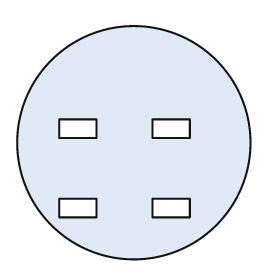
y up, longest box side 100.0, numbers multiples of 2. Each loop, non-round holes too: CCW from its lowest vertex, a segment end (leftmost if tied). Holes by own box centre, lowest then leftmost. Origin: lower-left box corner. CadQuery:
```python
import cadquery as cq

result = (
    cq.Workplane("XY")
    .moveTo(50.0, 50.0)
    .circle(50.0)
    .moveTo(18.0, 18.0)
    .lineTo(34.0, 18.0)
    .lineTo(34.0, 26.0)
    .lineTo(18.0, 26.0)
    .close()
    .moveTo(58.0, 18.0)
    .lineTo(74.0, 18.0)
    .lineTo(74.0, 26.0)
    .lineTo(58.0, 26.0)
    .close()
    .moveTo(18.0, 52.0)
    .lineTo(34.0, 52.0)
    .lineTo(34.0, 60.0)
    .lineTo(18.0, 60.0)
    .close()
    .moveTo(58.0, 52.0)
    .lineTo(74.0, 52.0)
    .lineTo(74.0, 60.0)
    .lineTo(58.0, 60.0)
    .close()
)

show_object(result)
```